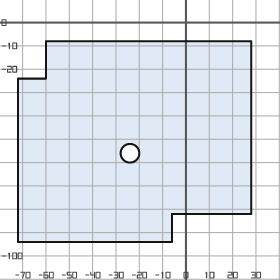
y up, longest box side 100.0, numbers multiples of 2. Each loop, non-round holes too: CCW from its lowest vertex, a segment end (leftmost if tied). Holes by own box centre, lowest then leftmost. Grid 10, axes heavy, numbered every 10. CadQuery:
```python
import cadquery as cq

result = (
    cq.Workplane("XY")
    .moveTo(-72.0, -94.0)
    .lineTo(-6.0, -94.0)
    .lineTo(-6.0, -82.0)
    .lineTo(28.0, -82.0)
    .lineTo(28.0, -8.0)
    .lineTo(-60.0, -8.0)
    .lineTo(-60.0, -24.0)
    .lineTo(-72.0, -24.0)
    .close()
    .moveTo(-24.0, -56.0)
    .circle(4.0)
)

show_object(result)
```